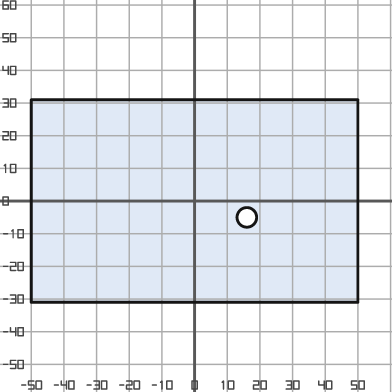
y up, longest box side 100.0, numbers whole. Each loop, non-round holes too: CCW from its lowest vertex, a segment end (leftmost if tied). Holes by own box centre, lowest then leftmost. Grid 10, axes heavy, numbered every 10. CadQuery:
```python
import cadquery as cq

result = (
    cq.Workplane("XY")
    .moveTo(-50.0, -31.0)
    .lineTo(50.0, -31.0)
    .lineTo(50.0, 31.0)
    .lineTo(-50.0, 31.0)
    .close()
    .moveTo(16.0, -5.0)
    .circle(3.0)
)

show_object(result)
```